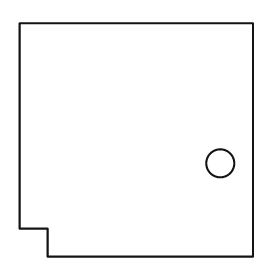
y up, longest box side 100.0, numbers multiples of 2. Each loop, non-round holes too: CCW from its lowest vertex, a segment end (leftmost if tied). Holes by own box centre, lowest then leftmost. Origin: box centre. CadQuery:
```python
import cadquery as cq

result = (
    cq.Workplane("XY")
    .moveTo(-38.0, -50.0)
    .lineTo(50.0, -50.0)
    .lineTo(50.0, 50.0)
    .lineTo(-50.0, 50.0)
    .lineTo(-50.0, -38.0)
    .lineTo(-38.0, -38.0)
    .close()
    .moveTo(36.0, -10.0)
    .circle(6.0)
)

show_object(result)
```